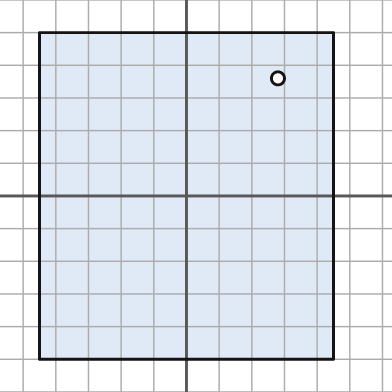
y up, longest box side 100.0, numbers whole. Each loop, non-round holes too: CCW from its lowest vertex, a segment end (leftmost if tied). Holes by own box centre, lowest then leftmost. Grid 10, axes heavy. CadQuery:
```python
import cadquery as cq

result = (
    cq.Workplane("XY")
    .moveTo(-45.0, -50.0)
    .lineTo(45.0, -50.0)
    .lineTo(45.0, 50.0)
    .lineTo(-45.0, 50.0)
    .close()
    .moveTo(28.0, 36.0)
    .circle(2.0)
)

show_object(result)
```